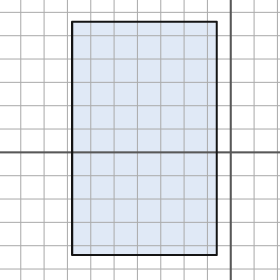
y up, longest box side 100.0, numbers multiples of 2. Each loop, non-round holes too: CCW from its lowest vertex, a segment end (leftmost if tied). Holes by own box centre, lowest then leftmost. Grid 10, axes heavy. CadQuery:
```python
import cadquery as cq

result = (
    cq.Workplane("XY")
    .moveTo(-68.0, -44.0)
    .lineTo(-6.0, -44.0)
    .lineTo(-6.0, 56.0)
    .lineTo(-68.0, 56.0)
    .close()
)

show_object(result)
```